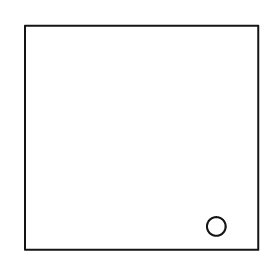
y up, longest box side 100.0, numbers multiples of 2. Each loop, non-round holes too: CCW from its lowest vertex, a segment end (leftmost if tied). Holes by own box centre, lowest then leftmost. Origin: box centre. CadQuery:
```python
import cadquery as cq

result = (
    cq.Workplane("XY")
    .moveTo(-50.0, -48.0)
    .lineTo(50.0, -48.0)
    .lineTo(50.0, 48.0)
    .lineTo(-50.0, 48.0)
    .close()
    .moveTo(32.0, -38.0)
    .circle(4.0)
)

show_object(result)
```